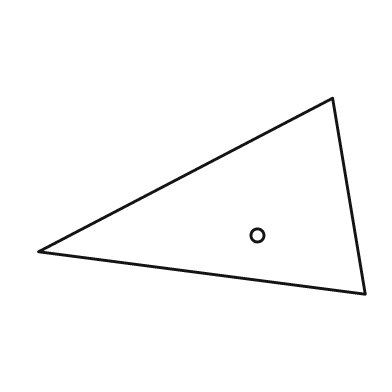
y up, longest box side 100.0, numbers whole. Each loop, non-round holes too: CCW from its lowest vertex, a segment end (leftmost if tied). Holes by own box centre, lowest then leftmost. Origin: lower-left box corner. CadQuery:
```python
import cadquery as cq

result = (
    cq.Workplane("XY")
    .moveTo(100.0, 0.0)
    .lineTo(90.0, 60.0)
    .lineTo(0.0, 13.0)
    .close()
    .moveTo(67.0, 18.0)
    .circle(2.0)
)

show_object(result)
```